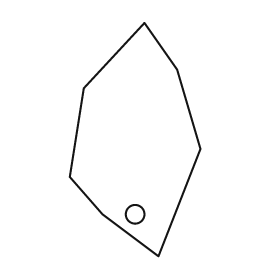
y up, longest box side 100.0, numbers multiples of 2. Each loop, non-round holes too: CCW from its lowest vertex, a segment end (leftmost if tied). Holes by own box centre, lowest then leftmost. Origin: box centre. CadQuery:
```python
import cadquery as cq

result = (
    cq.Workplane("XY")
    .moveTo(10.0, -50.0)
    .lineTo(28.0, -4.0)
    .lineTo(18.0, 30.0)
    .lineTo(4.0, 50.0)
    .lineTo(-22.0, 22.0)
    .lineTo(-28.0, -16.0)
    .lineTo(-14.0, -32.0)
    .close()
    .moveTo(0.0, -32.0)
    .circle(4.0)
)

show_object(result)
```